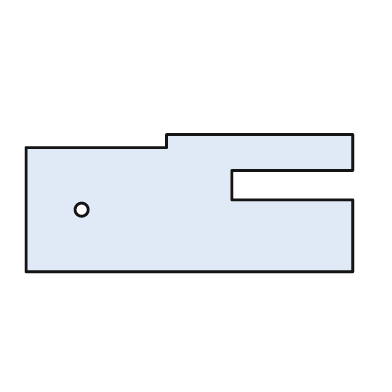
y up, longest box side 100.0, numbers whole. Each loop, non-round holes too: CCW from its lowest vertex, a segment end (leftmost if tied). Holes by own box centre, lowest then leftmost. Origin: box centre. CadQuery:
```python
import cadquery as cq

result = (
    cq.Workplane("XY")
    .moveTo(-50.0, -21.0)
    .lineTo(50.0, -21.0)
    .lineTo(50.0, 1.0)
    .lineTo(13.0, 1.0)
    .lineTo(13.0, 10.0)
    .lineTo(50.0, 10.0)
    .lineTo(50.0, 21.0)
    .lineTo(-7.0, 21.0)
    .lineTo(-7.0, 17.0)
    .lineTo(-50.0, 17.0)
    .close()
    .moveTo(-33.0, -2.0)
    .circle(2.0)
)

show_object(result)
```